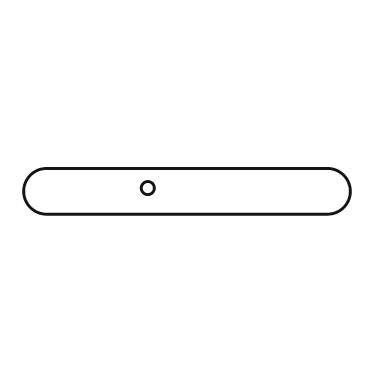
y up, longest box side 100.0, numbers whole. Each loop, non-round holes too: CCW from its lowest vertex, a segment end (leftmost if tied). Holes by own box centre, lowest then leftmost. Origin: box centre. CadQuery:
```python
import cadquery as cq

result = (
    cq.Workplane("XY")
    .moveTo(-43.0, -7.0)
    .lineTo(43.0, -7.0)
    .threePointArc((50.0, 0.0), (43.0, 7.0))
    .lineTo(-43.0, 7.0)
    .threePointArc((-50.0, 0.0), (-43.0, -7.0))
    .close()
    .moveTo(-12.0, 1.0)
    .circle(2.0)
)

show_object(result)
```